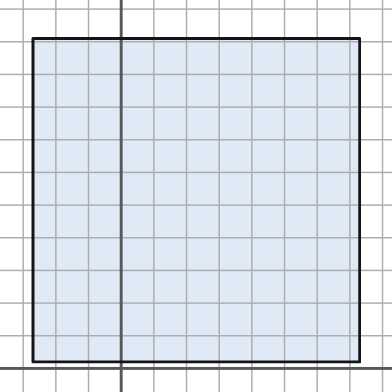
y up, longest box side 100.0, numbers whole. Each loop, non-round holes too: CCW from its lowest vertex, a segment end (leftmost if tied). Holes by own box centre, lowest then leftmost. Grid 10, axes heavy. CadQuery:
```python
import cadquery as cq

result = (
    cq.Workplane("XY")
    .moveTo(-27.0, 2.0)
    .lineTo(73.0, 2.0)
    .lineTo(73.0, 101.0)
    .lineTo(-27.0, 101.0)
    .close()
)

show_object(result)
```